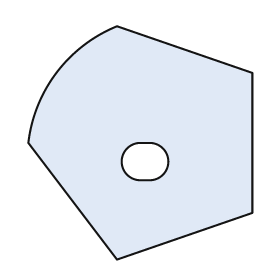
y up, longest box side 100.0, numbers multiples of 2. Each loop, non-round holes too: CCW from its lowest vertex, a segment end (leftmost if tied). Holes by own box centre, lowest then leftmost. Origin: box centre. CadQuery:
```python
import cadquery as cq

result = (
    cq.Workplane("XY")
    .moveTo(-10.0, -50.0)
    .lineTo(48.0, -30.0)
    .lineTo(48.0, 30.0)
    .lineTo(-10.0, 50.0)
    .threePointArc((-36.0, 30.0), (-48.0, 0.0))
    .close()
    .moveTo(0.0, -16.0)
    .lineTo(4.0, -16.0)
    .threePointArc((12.0, -8.0), (4.0, 0.0))
    .lineTo(0.0, 0.0)
    .threePointArc((-8.0, -8.0), (0.0, -16.0))
    .close()
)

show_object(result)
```